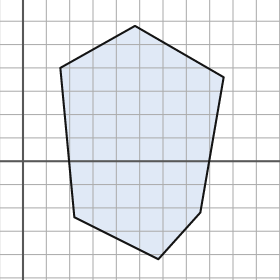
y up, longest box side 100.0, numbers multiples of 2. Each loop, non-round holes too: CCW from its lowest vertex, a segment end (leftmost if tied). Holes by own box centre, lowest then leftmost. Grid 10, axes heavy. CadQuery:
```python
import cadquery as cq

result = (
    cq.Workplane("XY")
    .moveTo(58.0, -42.0)
    .lineTo(76.0, -22.0)
    .lineTo(86.0, 36.0)
    .lineTo(48.0, 58.0)
    .lineTo(16.0, 40.0)
    .lineTo(22.0, -24.0)
    .close()
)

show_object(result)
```